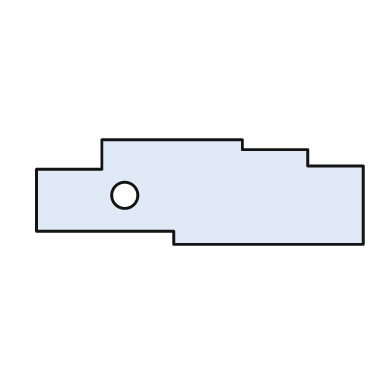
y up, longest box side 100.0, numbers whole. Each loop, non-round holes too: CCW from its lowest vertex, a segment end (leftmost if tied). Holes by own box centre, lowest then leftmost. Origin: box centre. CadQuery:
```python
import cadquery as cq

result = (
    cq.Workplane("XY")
    .moveTo(-8.0, -16.0)
    .lineTo(50.0, -16.0)
    .lineTo(50.0, 8.0)
    .lineTo(33.0, 8.0)
    .lineTo(33.0, 13.0)
    .lineTo(13.0, 13.0)
    .lineTo(13.0, 16.0)
    .lineTo(-30.0, 16.0)
    .lineTo(-30.0, 7.0)
    .lineTo(-50.0, 7.0)
    .lineTo(-50.0, -12.0)
    .lineTo(-8.0, -12.0)
    .close()
    .moveTo(-23.0, -1.0)
    .circle(4.0)
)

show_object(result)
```